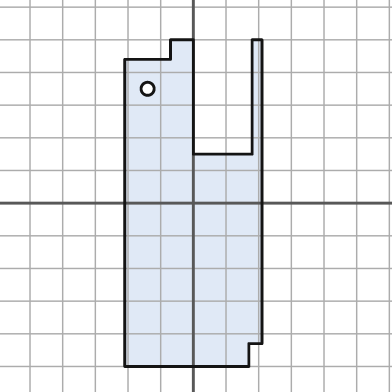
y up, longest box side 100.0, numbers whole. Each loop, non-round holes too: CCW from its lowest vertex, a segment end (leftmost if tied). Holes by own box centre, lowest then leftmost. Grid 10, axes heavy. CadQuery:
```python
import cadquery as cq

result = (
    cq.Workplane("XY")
    .moveTo(-21.0, -50.0)
    .lineTo(17.0, -50.0)
    .lineTo(17.0, -43.0)
    .lineTo(21.0, -43.0)
    .lineTo(21.0, 50.0)
    .lineTo(18.0, 50.0)
    .lineTo(18.0, 15.0)
    .lineTo(0.0, 15.0)
    .lineTo(0.0, 50.0)
    .lineTo(-7.0, 50.0)
    .lineTo(-7.0, 44.0)
    .lineTo(-21.0, 44.0)
    .close()
    .moveTo(-14.0, 35.0)
    .circle(2.0)
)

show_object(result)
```